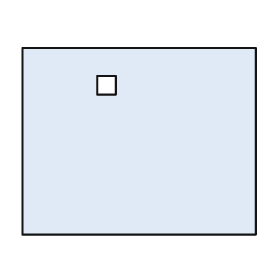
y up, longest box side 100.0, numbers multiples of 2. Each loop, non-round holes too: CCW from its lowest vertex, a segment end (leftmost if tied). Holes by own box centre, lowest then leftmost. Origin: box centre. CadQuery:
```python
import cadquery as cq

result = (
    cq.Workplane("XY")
    .moveTo(-50.0, -40.0)
    .lineTo(50.0, -40.0)
    .lineTo(50.0, 40.0)
    .lineTo(-50.0, 40.0)
    .close()
    .moveTo(-18.0, 20.0)
    .lineTo(-10.0, 20.0)
    .lineTo(-10.0, 28.0)
    .lineTo(-18.0, 28.0)
    .close()
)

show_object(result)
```